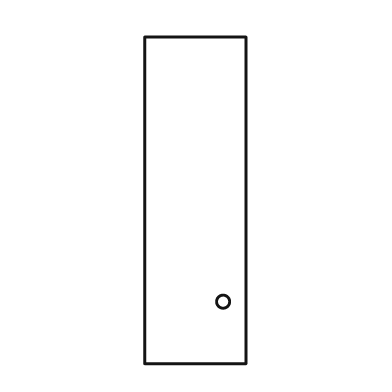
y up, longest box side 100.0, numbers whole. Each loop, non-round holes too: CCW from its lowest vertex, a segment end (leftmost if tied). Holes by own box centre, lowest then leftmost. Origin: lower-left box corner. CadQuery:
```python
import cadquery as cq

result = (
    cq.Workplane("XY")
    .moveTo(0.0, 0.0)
    .lineTo(31.0, 0.0)
    .lineTo(31.0, 100.0)
    .lineTo(0.0, 100.0)
    .close()
    .moveTo(24.0, 19.0)
    .circle(2.0)
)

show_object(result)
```